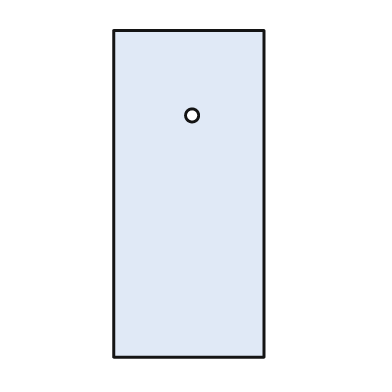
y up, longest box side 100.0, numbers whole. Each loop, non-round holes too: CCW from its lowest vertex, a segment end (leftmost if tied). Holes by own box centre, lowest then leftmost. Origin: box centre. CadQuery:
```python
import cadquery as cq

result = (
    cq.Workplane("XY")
    .moveTo(-23.0, -50.0)
    .lineTo(23.0, -50.0)
    .lineTo(23.0, 50.0)
    .lineTo(-23.0, 50.0)
    .close()
    .moveTo(1.0, 24.0)
    .circle(2.0)
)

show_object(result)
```